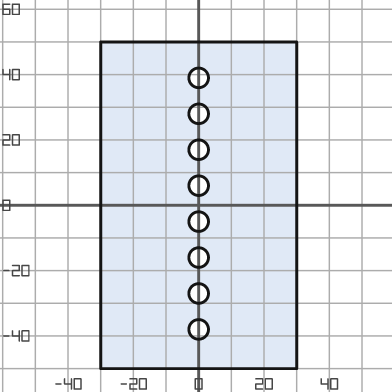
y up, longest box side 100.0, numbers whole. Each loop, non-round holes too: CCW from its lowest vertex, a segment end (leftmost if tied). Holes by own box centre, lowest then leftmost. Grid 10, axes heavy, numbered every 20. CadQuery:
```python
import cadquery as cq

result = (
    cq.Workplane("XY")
    .moveTo(-30.0, -50.0)
    .lineTo(30.0, -50.0)
    .lineTo(30.0, 50.0)
    .lineTo(-30.0, 50.0)
    .close()
    .moveTo(0.0, -38.0)
    .circle(3.0)
    .moveTo(0.0, -27.0)
    .circle(3.0)
    .moveTo(0.0, -16.0)
    .circle(3.0)
    .moveTo(0.0, -5.0)
    .circle(3.0)
    .moveTo(0.0, 6.0)
    .circle(3.0)
    .moveTo(0.0, 17.0)
    .circle(3.0)
    .moveTo(0.0, 28.0)
    .circle(3.0)
    .moveTo(0.0, 39.0)
    .circle(3.0)
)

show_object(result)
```